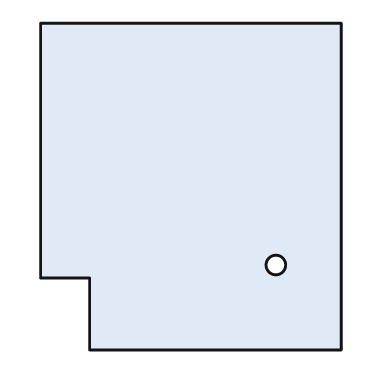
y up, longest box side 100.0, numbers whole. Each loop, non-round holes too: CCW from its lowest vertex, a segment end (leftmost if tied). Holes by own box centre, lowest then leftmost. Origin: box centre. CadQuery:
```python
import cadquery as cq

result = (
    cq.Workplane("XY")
    .moveTo(-31.0, -50.0)
    .lineTo(46.0, -50.0)
    .lineTo(46.0, 50.0)
    .lineTo(-46.0, 50.0)
    .lineTo(-46.0, -28.0)
    .lineTo(-31.0, -28.0)
    .close()
    .moveTo(26.0, -24.0)
    .circle(3.0)
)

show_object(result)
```